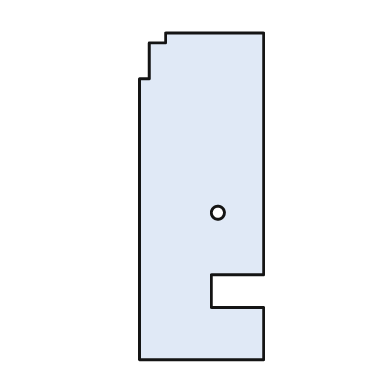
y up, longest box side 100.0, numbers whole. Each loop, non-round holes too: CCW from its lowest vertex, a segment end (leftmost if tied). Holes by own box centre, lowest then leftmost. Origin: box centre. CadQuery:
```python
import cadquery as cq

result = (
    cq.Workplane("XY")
    .moveTo(-19.0, -50.0)
    .lineTo(19.0, -50.0)
    .lineTo(19.0, -34.0)
    .lineTo(3.0, -34.0)
    .lineTo(3.0, -24.0)
    .lineTo(19.0, -24.0)
    .lineTo(19.0, 50.0)
    .lineTo(-11.0, 50.0)
    .lineTo(-11.0, 47.0)
    .lineTo(-16.0, 47.0)
    .lineTo(-16.0, 36.0)
    .lineTo(-19.0, 36.0)
    .close()
    .moveTo(5.0, -5.0)
    .circle(2.0)
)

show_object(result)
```